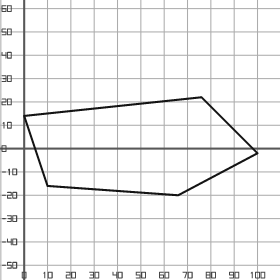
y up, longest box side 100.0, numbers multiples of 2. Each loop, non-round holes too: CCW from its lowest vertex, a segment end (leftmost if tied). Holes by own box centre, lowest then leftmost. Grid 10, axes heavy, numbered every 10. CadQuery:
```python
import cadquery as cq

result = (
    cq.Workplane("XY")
    .moveTo(66.0, -20.0)
    .lineTo(100.0, -2.0)
    .lineTo(76.0, 22.0)
    .lineTo(0.0, 14.0)
    .lineTo(10.0, -16.0)
    .close()
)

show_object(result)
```